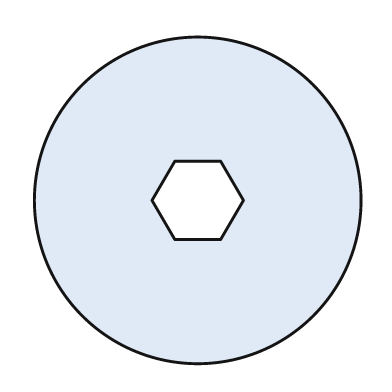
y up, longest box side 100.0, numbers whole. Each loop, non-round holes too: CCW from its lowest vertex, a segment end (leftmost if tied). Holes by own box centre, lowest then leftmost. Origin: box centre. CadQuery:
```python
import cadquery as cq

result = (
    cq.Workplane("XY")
    .moveTo(0.0, 0.0)
    .circle(50.0)
    .moveTo(-7.0, -12.0)
    .lineTo(7.0, -12.0)
    .lineTo(14.0, 0.0)
    .lineTo(7.0, 12.0)
    .lineTo(-7.0, 12.0)
    .lineTo(-14.0, 0.0)
    .close()
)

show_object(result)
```